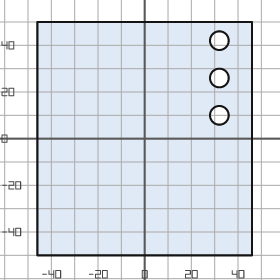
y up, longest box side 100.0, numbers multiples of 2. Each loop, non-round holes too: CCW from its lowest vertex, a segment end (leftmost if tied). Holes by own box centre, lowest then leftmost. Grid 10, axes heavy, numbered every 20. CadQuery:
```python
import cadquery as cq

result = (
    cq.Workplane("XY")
    .moveTo(-46.0, -50.0)
    .lineTo(46.0, -50.0)
    .lineTo(46.0, 50.0)
    .lineTo(-46.0, 50.0)
    .close()
    .moveTo(32.0, 10.0)
    .circle(4.0)
    .moveTo(32.0, 26.0)
    .circle(4.0)
    .moveTo(32.0, 42.0)
    .circle(4.0)
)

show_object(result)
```